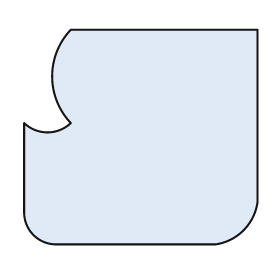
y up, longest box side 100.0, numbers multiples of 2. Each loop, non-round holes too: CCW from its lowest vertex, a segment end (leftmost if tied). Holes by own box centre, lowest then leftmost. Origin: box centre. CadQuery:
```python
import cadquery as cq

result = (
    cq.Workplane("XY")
    .moveTo(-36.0, -46.0)
    .lineTo(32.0, -46.0)
    .threePointArc((44.0, -40.0), (50.0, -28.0))
    .lineTo(50.0, 46.0)
    .lineTo(-30.0, 46.0)
    .threePointArc((-38.0, 26.0), (-30.0, 6.0))
    .threePointArc((-40.0, 2.0), (-50.0, 6.0))
    .lineTo(-50.0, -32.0)
    .threePointArc((-46.0, -42.0), (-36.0, -46.0))
    .close()
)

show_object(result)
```